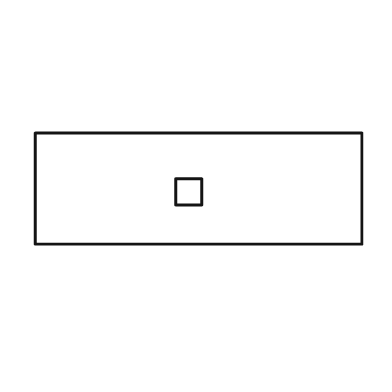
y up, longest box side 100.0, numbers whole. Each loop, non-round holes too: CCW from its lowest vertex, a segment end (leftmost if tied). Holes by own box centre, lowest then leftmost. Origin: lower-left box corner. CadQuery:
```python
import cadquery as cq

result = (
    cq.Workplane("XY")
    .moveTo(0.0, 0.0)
    .lineTo(100.0, 0.0)
    .lineTo(100.0, 34.0)
    .lineTo(0.0, 34.0)
    .close()
    .moveTo(43.0, 12.0)
    .lineTo(51.0, 12.0)
    .lineTo(51.0, 20.0)
    .lineTo(43.0, 20.0)
    .close()
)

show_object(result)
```